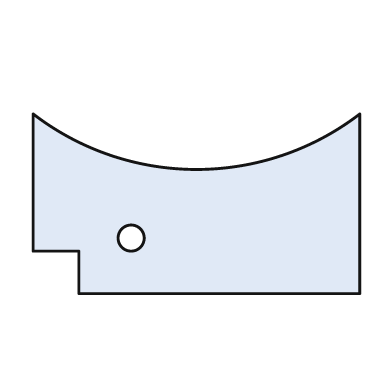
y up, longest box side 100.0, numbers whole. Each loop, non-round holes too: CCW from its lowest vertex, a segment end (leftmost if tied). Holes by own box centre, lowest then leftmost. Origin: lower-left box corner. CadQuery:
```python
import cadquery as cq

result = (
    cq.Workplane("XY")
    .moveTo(14.0, 0.0)
    .lineTo(100.0, 0.0)
    .lineTo(100.0, 55.0)
    .threePointArc((50.0, 38.0), (0.0, 55.0))
    .lineTo(0.0, 13.0)
    .lineTo(14.0, 13.0)
    .close()
    .moveTo(30.0, 17.0)
    .circle(4.0)
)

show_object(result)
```